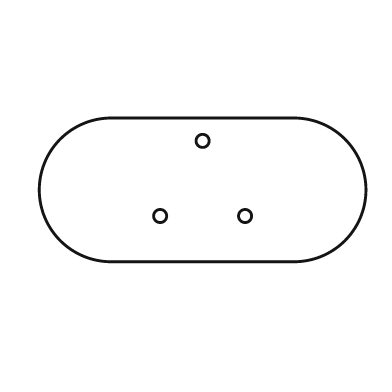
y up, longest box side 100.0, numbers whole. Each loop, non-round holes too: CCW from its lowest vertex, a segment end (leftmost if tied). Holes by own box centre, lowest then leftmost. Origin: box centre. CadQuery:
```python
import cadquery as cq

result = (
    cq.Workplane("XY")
    .moveTo(-28.0, -22.0)
    .lineTo(28.0, -22.0)
    .threePointArc((50.0, 0.0), (28.0, 22.0))
    .lineTo(-28.0, 22.0)
    .threePointArc((-50.0, 0.0), (-28.0, -22.0))
    .close()
    .moveTo(-13.0, -8.0)
    .circle(2.0)
    .moveTo(13.0, -8.0)
    .circle(2.0)
    .moveTo(0.0, 15.0)
    .circle(2.0)
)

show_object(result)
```